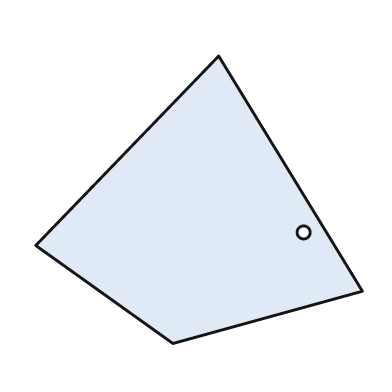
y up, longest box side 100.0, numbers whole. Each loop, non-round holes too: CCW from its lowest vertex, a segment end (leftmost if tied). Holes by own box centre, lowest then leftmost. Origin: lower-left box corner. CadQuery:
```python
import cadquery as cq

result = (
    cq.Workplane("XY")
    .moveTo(42.0, 0.0)
    .lineTo(100.0, 16.0)
    .lineTo(56.0, 88.0)
    .lineTo(0.0, 30.0)
    .close()
    .moveTo(82.0, 34.0)
    .circle(2.0)
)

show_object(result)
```